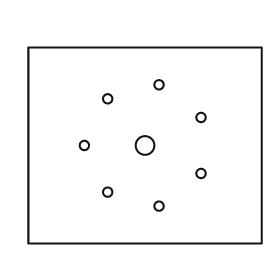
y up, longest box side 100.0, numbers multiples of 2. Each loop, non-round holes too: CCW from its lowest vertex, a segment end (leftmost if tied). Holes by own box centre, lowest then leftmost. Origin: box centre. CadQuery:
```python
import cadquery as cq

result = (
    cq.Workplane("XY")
    .moveTo(-50.0, -42.0)
    .lineTo(50.0, -42.0)
    .lineTo(50.0, 42.0)
    .lineTo(-50.0, 42.0)
    .close()
    .moveTo(6.0, -26.0)
    .circle(2.0)
    .moveTo(-16.0, -20.0)
    .circle(2.0)
    .moveTo(24.0, -12.0)
    .circle(2.0)
    .moveTo(-26.0, 0.0)
    .circle(2.0)
    .moveTo(0.0, 0.0)
    .circle(4.0)
    .moveTo(24.0, 12.0)
    .circle(2.0)
    .moveTo(-16.0, 20.0)
    .circle(2.0)
    .moveTo(6.0, 26.0)
    .circle(2.0)
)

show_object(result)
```